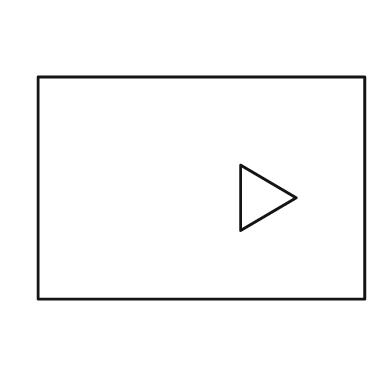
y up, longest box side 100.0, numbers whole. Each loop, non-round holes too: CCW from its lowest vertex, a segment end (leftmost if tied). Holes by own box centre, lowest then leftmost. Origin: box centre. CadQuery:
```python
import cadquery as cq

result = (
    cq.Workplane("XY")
    .moveTo(-50.0, -34.0)
    .lineTo(50.0, -34.0)
    .lineTo(50.0, 34.0)
    .lineTo(-50.0, 34.0)
    .close()
    .moveTo(12.0, -13.0)
    .lineTo(29.0, -3.0)
    .lineTo(12.0, 7.0)
    .close()
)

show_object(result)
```